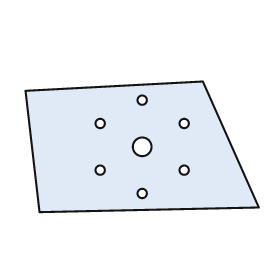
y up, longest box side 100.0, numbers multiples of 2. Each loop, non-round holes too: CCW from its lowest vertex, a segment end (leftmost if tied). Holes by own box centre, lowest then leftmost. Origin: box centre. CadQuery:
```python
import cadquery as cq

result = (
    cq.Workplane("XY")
    .moveTo(-44.0, -28.0)
    .lineTo(50.0, -26.0)
    .lineTo(26.0, 28.0)
    .lineTo(-50.0, 24.0)
    .close()
    .moveTo(0.0, -20.0)
    .circle(2.0)
    .moveTo(-18.0, -10.0)
    .circle(2.0)
    .moveTo(18.0, -10.0)
    .circle(2.0)
    .moveTo(0.0, 0.0)
    .circle(4.0)
    .moveTo(-18.0, 10.0)
    .circle(2.0)
    .moveTo(18.0, 10.0)
    .circle(2.0)
    .moveTo(0.0, 20.0)
    .circle(2.0)
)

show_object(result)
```